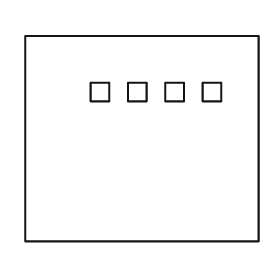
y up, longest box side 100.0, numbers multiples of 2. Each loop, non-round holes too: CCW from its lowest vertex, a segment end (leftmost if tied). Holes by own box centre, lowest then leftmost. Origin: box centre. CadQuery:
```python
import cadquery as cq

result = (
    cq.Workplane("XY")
    .moveTo(-50.0, -44.0)
    .lineTo(50.0, -44.0)
    .lineTo(50.0, 44.0)
    .lineTo(-50.0, 44.0)
    .close()
    .moveTo(-22.0, 16.0)
    .lineTo(-14.0, 16.0)
    .lineTo(-14.0, 24.0)
    .lineTo(-22.0, 24.0)
    .close()
    .moveTo(-6.0, 16.0)
    .lineTo(2.0, 16.0)
    .lineTo(2.0, 24.0)
    .lineTo(-6.0, 24.0)
    .close()
    .moveTo(10.0, 16.0)
    .lineTo(18.0, 16.0)
    .lineTo(18.0, 24.0)
    .lineTo(10.0, 24.0)
    .close()
    .moveTo(26.0, 16.0)
    .lineTo(34.0, 16.0)
    .lineTo(34.0, 24.0)
    .lineTo(26.0, 24.0)
    .close()
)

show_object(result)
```